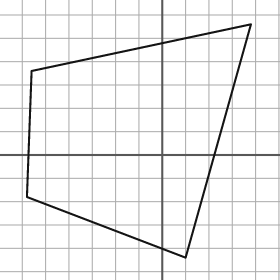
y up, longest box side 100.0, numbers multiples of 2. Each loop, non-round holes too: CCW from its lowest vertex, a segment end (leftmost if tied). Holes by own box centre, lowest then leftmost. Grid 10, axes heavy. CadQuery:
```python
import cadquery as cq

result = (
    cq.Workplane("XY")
    .moveTo(10.0, -44.0)
    .lineTo(38.0, 56.0)
    .lineTo(-56.0, 36.0)
    .lineTo(-58.0, -18.0)
    .close()
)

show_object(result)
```